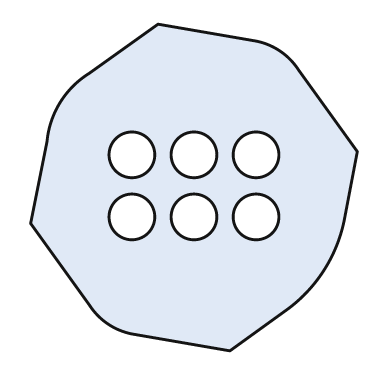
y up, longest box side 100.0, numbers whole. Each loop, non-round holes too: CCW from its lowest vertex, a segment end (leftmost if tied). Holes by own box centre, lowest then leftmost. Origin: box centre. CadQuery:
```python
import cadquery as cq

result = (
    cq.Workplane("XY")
    .moveTo(11.0, -50.0)
    .lineTo(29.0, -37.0)
    .threePointArc((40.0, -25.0), (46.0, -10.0))
    .lineTo(50.0, 11.0)
    .lineTo(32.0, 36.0)
    .threePointArc((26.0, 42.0), (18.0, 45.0))
    .lineTo(-11.0, 50.0)
    .lineTo(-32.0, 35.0)
    .threePointArc((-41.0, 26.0), (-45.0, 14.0))
    .lineTo(-50.0, -11.0)
    .lineTo(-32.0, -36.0)
    .threePointArc((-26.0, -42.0), (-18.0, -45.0))
    .close()
    .moveTo(-19.0, -9.0)
    .circle(7.0)
    .moveTo(0.0, -9.0)
    .circle(7.0)
    .moveTo(19.0, -9.0)
    .circle(7.0)
    .moveTo(-19.0, 10.0)
    .circle(7.0)
    .moveTo(0.0, 10.0)
    .circle(7.0)
    .moveTo(19.0, 10.0)
    .circle(7.0)
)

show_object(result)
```